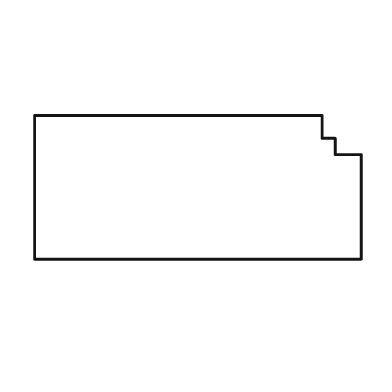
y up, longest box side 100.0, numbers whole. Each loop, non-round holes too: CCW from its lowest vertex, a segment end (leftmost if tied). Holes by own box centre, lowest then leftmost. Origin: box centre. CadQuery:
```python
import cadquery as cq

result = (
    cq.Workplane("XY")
    .moveTo(-50.0, -22.0)
    .lineTo(50.0, -22.0)
    .lineTo(50.0, 10.0)
    .lineTo(42.0, 10.0)
    .lineTo(42.0, 15.0)
    .lineTo(38.0, 15.0)
    .lineTo(38.0, 22.0)
    .lineTo(-50.0, 22.0)
    .close()
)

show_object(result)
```